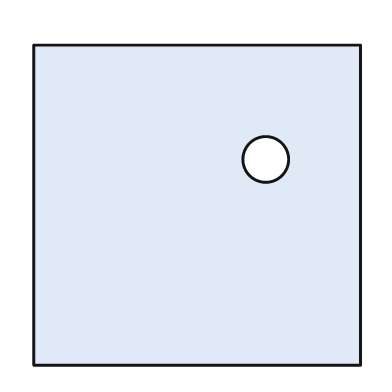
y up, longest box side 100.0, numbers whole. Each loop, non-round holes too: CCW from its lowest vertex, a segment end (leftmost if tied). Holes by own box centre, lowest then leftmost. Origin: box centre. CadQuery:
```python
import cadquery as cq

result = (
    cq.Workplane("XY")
    .moveTo(-50.0, -49.0)
    .lineTo(50.0, -49.0)
    .lineTo(50.0, 49.0)
    .lineTo(-50.0, 49.0)
    .close()
    .moveTo(21.0, 14.0)
    .circle(7.0)
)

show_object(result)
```